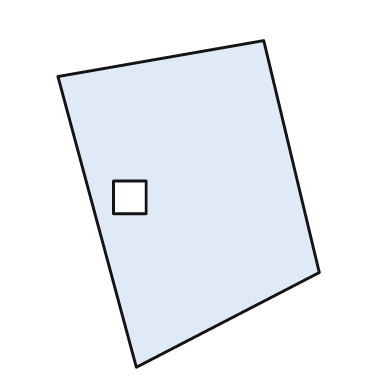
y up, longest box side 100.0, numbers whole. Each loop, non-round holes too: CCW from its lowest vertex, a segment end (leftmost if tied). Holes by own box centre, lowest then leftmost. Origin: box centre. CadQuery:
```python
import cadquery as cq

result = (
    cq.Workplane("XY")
    .moveTo(-16.0, -50.0)
    .lineTo(40.0, -21.0)
    .lineTo(23.0, 50.0)
    .lineTo(-40.0, 39.0)
    .close()
    .moveTo(-23.0, -3.0)
    .lineTo(-13.0, -3.0)
    .lineTo(-13.0, 7.0)
    .lineTo(-23.0, 7.0)
    .close()
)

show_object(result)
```